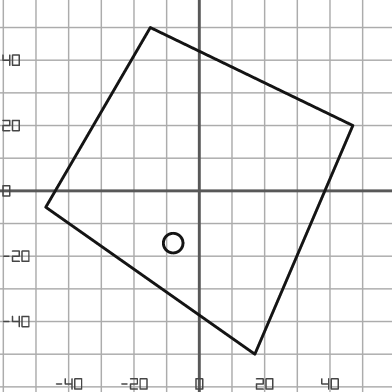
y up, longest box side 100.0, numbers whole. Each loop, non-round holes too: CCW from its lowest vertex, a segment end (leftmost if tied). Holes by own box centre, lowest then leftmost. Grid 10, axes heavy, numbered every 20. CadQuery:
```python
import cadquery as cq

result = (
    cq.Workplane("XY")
    .moveTo(17.0, -50.0)
    .lineTo(47.0, 20.0)
    .lineTo(-15.0, 50.0)
    .lineTo(-47.0, -5.0)
    .close()
    .moveTo(-8.0, -16.0)
    .circle(3.0)
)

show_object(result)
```